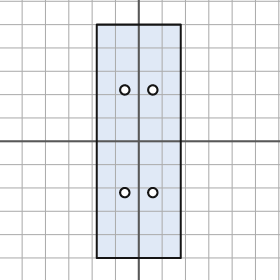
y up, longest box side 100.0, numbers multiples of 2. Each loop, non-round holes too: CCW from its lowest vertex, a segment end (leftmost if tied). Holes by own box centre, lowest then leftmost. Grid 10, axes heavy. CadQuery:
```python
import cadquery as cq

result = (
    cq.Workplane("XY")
    .moveTo(-18.0, -50.0)
    .lineTo(18.0, -50.0)
    .lineTo(18.0, 50.0)
    .lineTo(-18.0, 50.0)
    .close()
    .moveTo(-6.0, -22.0)
    .circle(2.0)
    .moveTo(6.0, -22.0)
    .circle(2.0)
    .moveTo(-6.0, 22.0)
    .circle(2.0)
    .moveTo(6.0, 22.0)
    .circle(2.0)
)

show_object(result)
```